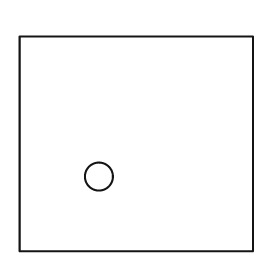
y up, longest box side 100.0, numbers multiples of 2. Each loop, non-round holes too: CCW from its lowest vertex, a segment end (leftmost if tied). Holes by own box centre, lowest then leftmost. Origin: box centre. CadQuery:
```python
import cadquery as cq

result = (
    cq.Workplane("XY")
    .moveTo(-50.0, -46.0)
    .lineTo(50.0, -46.0)
    .lineTo(50.0, 46.0)
    .lineTo(-50.0, 46.0)
    .close()
    .moveTo(-16.0, -14.0)
    .circle(6.0)
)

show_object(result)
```